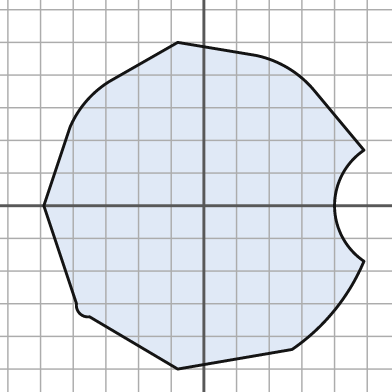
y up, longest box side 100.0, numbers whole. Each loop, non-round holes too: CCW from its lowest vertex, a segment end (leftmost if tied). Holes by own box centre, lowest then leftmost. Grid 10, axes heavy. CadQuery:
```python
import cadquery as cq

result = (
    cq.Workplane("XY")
    .moveTo(-8.0, -50.0)
    .lineTo(27.0, -44.0)
    .threePointArc((40.0, -32.0), (49.0, -17.0))
    .threePointArc((40.0, 0.0), (49.0, 17.0))
    .lineTo(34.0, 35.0)
    .threePointArc((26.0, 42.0), (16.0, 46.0))
    .lineTo(-8.0, 50.0)
    .lineTo(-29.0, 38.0)
    .threePointArc((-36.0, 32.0), (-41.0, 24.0))
    .lineTo(-49.0, 0.0)
    .lineTo(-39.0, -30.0)
    .threePointArc((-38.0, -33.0), (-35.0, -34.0))
    .close()
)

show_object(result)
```